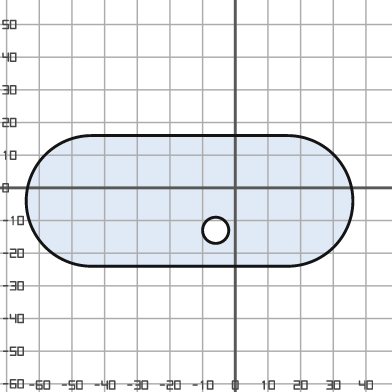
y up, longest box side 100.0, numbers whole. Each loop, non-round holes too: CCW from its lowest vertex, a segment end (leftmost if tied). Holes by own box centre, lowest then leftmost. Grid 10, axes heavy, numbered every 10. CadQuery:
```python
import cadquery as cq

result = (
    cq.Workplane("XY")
    .moveTo(-44.0, -24.0)
    .lineTo(16.0, -24.0)
    .threePointArc((36.0, -4.0), (16.0, 16.0))
    .lineTo(-44.0, 16.0)
    .threePointArc((-64.0, -4.0), (-44.0, -24.0))
    .close()
    .moveTo(-6.0, -13.0)
    .circle(4.0)
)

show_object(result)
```